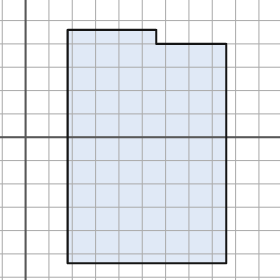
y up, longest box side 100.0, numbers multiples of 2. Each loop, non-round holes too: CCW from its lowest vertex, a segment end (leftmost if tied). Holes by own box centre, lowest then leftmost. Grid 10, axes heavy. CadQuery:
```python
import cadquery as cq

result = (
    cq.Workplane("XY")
    .moveTo(18.0, -54.0)
    .lineTo(86.0, -54.0)
    .lineTo(86.0, 40.0)
    .lineTo(56.0, 40.0)
    .lineTo(56.0, 46.0)
    .lineTo(18.0, 46.0)
    .close()
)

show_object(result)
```